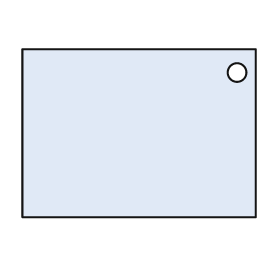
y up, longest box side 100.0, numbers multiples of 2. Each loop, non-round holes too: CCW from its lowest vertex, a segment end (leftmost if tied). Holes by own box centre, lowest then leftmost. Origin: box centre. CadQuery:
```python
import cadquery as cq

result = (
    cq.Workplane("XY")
    .moveTo(-50.0, -36.0)
    .lineTo(50.0, -36.0)
    .lineTo(50.0, 36.0)
    .lineTo(-50.0, 36.0)
    .close()
    .moveTo(42.0, 26.0)
    .circle(4.0)
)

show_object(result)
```